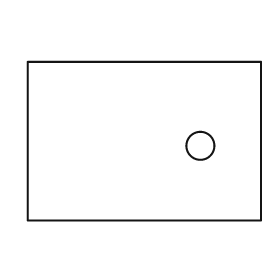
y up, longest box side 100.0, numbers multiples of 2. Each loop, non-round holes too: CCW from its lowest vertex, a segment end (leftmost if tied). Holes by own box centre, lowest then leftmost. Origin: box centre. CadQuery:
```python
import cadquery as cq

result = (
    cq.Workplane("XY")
    .moveTo(-50.0, -34.0)
    .lineTo(50.0, -34.0)
    .lineTo(50.0, 34.0)
    .lineTo(-50.0, 34.0)
    .close()
    .moveTo(24.0, -2.0)
    .circle(6.0)
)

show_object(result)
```